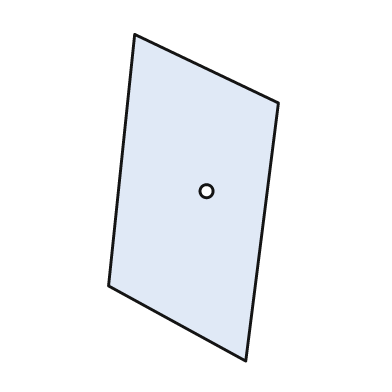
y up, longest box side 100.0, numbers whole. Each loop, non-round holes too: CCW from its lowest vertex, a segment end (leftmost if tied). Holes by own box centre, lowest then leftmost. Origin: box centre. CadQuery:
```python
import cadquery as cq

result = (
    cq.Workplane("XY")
    .moveTo(16.0, -50.0)
    .lineTo(26.0, 29.0)
    .lineTo(-18.0, 50.0)
    .lineTo(-26.0, -27.0)
    .close()
    .moveTo(4.0, 2.0)
    .circle(2.0)
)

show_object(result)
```